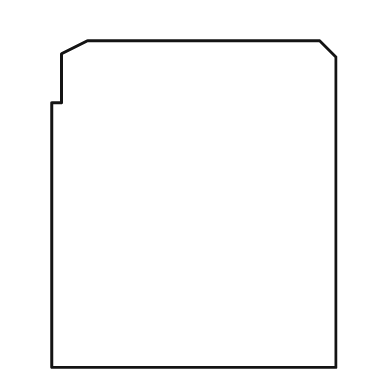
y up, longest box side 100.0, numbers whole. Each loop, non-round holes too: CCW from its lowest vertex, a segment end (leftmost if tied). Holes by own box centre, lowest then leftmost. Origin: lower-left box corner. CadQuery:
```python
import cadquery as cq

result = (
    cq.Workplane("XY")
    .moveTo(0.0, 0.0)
    .lineTo(87.0, 0.0)
    .lineTo(87.0, 95.0)
    .lineTo(82.0, 100.0)
    .lineTo(11.0, 100.0)
    .lineTo(3.0, 96.0)
    .lineTo(3.0, 81.0)
    .lineTo(0.0, 81.0)
    .close()
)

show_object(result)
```